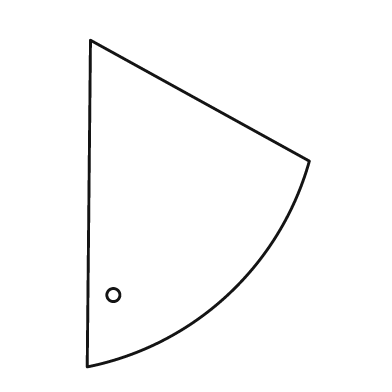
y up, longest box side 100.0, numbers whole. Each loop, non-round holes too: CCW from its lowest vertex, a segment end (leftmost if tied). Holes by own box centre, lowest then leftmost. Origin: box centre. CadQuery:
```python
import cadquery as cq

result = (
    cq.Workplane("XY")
    .moveTo(-34.0, -50.0)
    .threePointArc((9.0, -28.0), (34.0, 13.0))
    .lineTo(-33.0, 50.0)
    .close()
    .moveTo(-26.0, -28.0)
    .circle(2.0)
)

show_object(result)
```